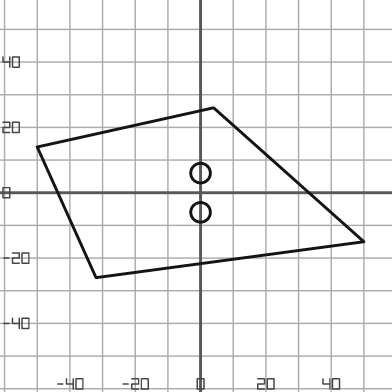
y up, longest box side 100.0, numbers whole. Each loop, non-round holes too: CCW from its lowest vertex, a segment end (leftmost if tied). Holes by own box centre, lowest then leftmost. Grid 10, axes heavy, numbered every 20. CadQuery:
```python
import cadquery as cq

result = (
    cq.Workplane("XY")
    .moveTo(-32.0, -26.0)
    .lineTo(50.0, -15.0)
    .lineTo(4.0, 26.0)
    .lineTo(-50.0, 14.0)
    .close()
    .moveTo(0.0, -6.0)
    .circle(3.0)
    .moveTo(0.0, 6.0)
    .circle(3.0)
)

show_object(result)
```